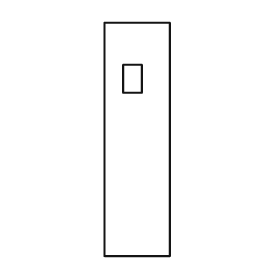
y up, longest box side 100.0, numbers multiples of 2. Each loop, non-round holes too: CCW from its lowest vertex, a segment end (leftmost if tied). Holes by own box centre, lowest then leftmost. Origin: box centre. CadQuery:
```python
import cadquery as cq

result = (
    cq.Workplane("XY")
    .moveTo(-14.0, -50.0)
    .lineTo(14.0, -50.0)
    .lineTo(14.0, 50.0)
    .lineTo(-14.0, 50.0)
    .close()
    .moveTo(-6.0, 20.0)
    .lineTo(2.0, 20.0)
    .lineTo(2.0, 32.0)
    .lineTo(-6.0, 32.0)
    .close()
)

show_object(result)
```